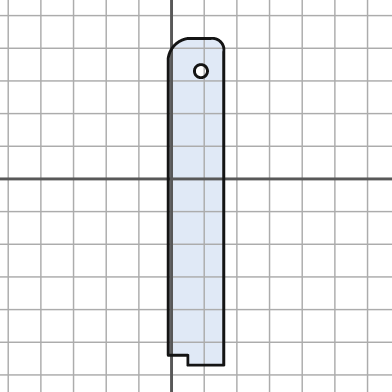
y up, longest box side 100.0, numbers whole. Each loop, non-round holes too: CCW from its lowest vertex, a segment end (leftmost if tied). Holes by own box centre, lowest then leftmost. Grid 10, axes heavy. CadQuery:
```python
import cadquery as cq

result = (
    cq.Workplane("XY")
    .moveTo(5.0, -57.0)
    .lineTo(16.0, -57.0)
    .lineTo(16.0, 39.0)
    .threePointArc((15.0, 42.0), (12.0, 43.0))
    .lineTo(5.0, 43.0)
    .threePointArc((1.0, 41.0), (-1.0, 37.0))
    .lineTo(-1.0, -54.0)
    .lineTo(5.0, -54.0)
    .close()
    .moveTo(9.0, 33.0)
    .circle(2.0)
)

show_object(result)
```